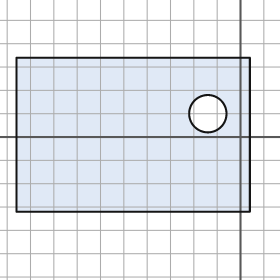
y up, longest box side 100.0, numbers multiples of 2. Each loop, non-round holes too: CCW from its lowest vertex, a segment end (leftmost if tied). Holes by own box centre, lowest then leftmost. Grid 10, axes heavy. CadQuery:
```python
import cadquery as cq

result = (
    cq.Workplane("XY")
    .moveTo(-96.0, -32.0)
    .lineTo(4.0, -32.0)
    .lineTo(4.0, 34.0)
    .lineTo(-96.0, 34.0)
    .close()
    .moveTo(-14.0, 10.0)
    .circle(8.0)
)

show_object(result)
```